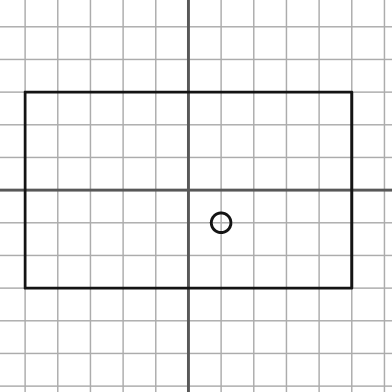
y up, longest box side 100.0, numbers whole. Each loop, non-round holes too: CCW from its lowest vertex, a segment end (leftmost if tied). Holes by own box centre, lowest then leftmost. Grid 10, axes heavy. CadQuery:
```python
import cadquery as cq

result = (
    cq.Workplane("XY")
    .moveTo(-50.0, -30.0)
    .lineTo(50.0, -30.0)
    .lineTo(50.0, 30.0)
    .lineTo(-50.0, 30.0)
    .close()
    .moveTo(10.0, -10.0)
    .circle(3.0)
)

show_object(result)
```